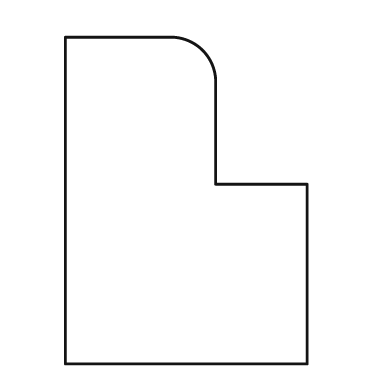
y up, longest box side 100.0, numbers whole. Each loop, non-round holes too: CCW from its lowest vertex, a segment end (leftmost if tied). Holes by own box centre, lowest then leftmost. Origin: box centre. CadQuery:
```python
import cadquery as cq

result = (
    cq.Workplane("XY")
    .moveTo(-37.0, -50.0)
    .lineTo(37.0, -50.0)
    .lineTo(37.0, 5.0)
    .lineTo(9.0, 5.0)
    .lineTo(9.0, 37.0)
    .threePointArc((5.0, 46.0), (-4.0, 50.0))
    .lineTo(-37.0, 50.0)
    .close()
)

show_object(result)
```